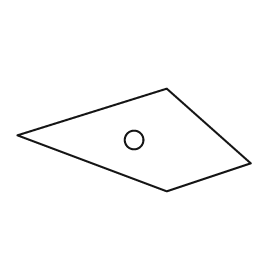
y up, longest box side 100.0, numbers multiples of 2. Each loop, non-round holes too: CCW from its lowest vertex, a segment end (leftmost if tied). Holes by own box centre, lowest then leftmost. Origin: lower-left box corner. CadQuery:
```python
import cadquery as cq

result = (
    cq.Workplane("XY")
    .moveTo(64.0, 0.0)
    .lineTo(100.0, 12.0)
    .lineTo(64.0, 44.0)
    .lineTo(0.0, 24.0)
    .close()
    .moveTo(50.0, 22.0)
    .circle(4.0)
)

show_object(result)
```